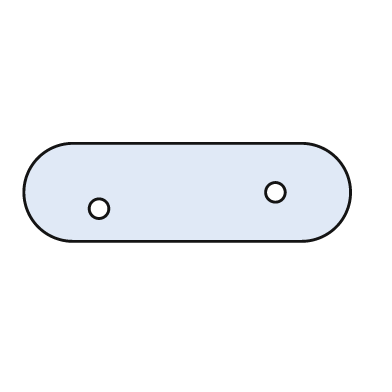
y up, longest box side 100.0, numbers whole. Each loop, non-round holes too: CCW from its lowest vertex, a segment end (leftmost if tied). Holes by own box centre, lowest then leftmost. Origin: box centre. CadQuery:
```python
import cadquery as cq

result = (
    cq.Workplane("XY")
    .moveTo(-35.0, -15.0)
    .lineTo(35.0, -15.0)
    .threePointArc((50.0, 0.0), (35.0, 15.0))
    .lineTo(-35.0, 15.0)
    .threePointArc((-50.0, 0.0), (-35.0, -15.0))
    .close()
    .moveTo(-27.0, -5.0)
    .circle(3.0)
    .moveTo(27.0, 0.0)
    .circle(3.0)
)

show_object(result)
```